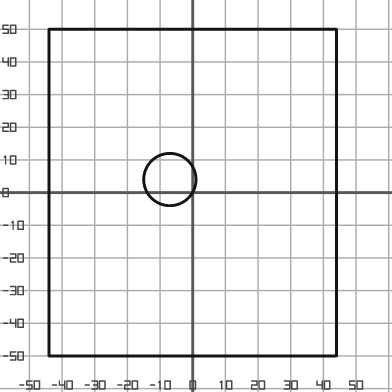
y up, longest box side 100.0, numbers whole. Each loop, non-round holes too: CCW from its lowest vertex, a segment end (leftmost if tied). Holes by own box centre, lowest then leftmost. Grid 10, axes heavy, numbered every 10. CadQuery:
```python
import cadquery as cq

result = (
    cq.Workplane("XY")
    .moveTo(-44.0, -50.0)
    .lineTo(44.0, -50.0)
    .lineTo(44.0, 50.0)
    .lineTo(-44.0, 50.0)
    .close()
    .moveTo(-7.0, 4.0)
    .circle(8.0)
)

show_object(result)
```